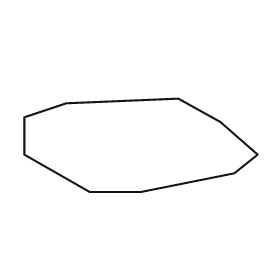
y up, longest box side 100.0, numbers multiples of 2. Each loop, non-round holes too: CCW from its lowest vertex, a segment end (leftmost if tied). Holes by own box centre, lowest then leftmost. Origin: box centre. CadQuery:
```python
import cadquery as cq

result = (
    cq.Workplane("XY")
    .moveTo(-22.0, -20.0)
    .lineTo(0.0, -20.0)
    .lineTo(40.0, -12.0)
    .lineTo(50.0, -4.0)
    .lineTo(34.0, 10.0)
    .lineTo(16.0, 20.0)
    .lineTo(-32.0, 18.0)
    .lineTo(-50.0, 12.0)
    .lineTo(-50.0, -4.0)
    .close()
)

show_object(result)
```